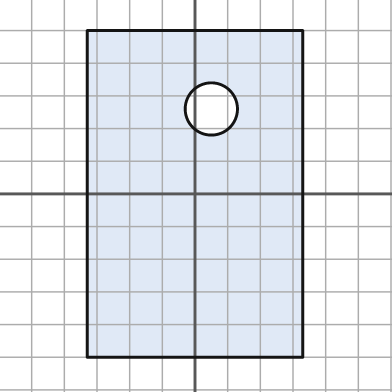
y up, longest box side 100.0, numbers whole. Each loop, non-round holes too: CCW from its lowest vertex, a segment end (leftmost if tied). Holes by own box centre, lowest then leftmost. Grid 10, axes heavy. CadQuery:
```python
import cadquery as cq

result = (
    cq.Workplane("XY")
    .moveTo(-33.0, -50.0)
    .lineTo(33.0, -50.0)
    .lineTo(33.0, 50.0)
    .lineTo(-33.0, 50.0)
    .close()
    .moveTo(5.0, 26.0)
    .circle(8.0)
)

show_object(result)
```